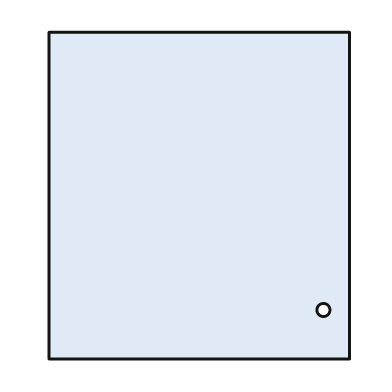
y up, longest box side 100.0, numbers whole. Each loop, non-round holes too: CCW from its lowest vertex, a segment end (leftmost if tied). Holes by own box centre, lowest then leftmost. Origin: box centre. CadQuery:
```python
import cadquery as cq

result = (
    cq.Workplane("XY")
    .moveTo(-46.0, -50.0)
    .lineTo(46.0, -50.0)
    .lineTo(46.0, 50.0)
    .lineTo(-46.0, 50.0)
    .close()
    .moveTo(38.0, -35.0)
    .circle(2.0)
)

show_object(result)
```